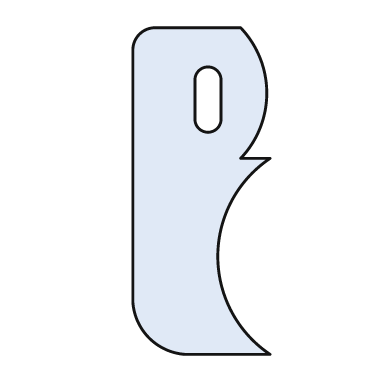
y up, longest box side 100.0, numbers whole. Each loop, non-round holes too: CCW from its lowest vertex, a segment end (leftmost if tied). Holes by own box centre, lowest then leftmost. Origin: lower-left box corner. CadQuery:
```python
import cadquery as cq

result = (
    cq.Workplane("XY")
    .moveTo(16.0, 0.0)
    .lineTo(42.0, 0.0)
    .threePointArc((26.0, 30.0), (42.0, 60.0))
    .lineTo(33.0, 60.0)
    .threePointArc((41.0, 80.0), (33.0, 100.0))
    .lineTo(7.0, 100.0)
    .threePointArc((2.0, 98.0), (0.0, 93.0))
    .lineTo(0.0, 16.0)
    .threePointArc((5.0, 5.0), (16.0, 0.0))
    .close()
    .moveTo(19.0, 72.0)
    .threePointArc((23.0, 68.0), (27.0, 72.0))
    .lineTo(27.0, 84.0)
    .threePointArc((23.0, 88.0), (19.0, 84.0))
    .close()
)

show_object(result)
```